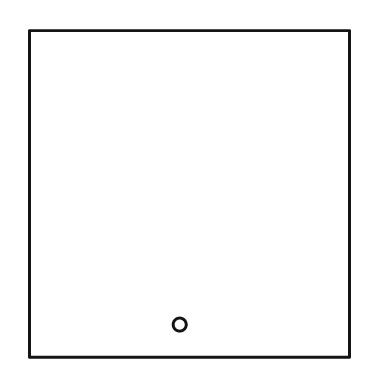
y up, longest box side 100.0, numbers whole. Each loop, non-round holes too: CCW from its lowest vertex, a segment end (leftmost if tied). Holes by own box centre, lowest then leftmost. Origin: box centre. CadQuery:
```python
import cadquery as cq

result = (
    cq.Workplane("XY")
    .moveTo(-49.0, -50.0)
    .lineTo(49.0, -50.0)
    .lineTo(49.0, 50.0)
    .lineTo(-49.0, 50.0)
    .close()
    .moveTo(-3.0, -40.0)
    .circle(2.0)
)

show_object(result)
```